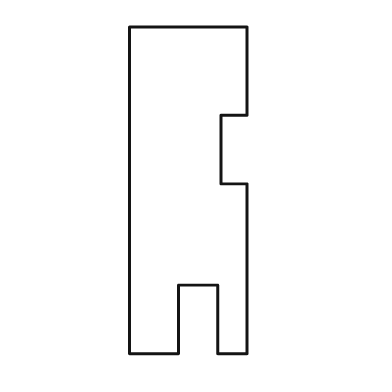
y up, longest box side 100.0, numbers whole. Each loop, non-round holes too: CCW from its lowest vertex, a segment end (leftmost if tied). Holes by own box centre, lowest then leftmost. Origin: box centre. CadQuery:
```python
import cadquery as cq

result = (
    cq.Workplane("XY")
    .moveTo(-18.0, -50.0)
    .lineTo(-3.0, -50.0)
    .lineTo(-3.0, -29.0)
    .lineTo(9.0, -29.0)
    .lineTo(9.0, -50.0)
    .lineTo(18.0, -50.0)
    .lineTo(18.0, 2.0)
    .lineTo(10.0, 2.0)
    .lineTo(10.0, 23.0)
    .lineTo(18.0, 23.0)
    .lineTo(18.0, 50.0)
    .lineTo(-18.0, 50.0)
    .close()
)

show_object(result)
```